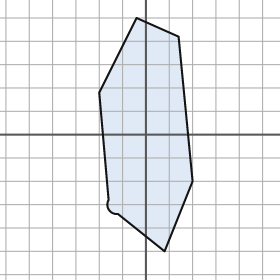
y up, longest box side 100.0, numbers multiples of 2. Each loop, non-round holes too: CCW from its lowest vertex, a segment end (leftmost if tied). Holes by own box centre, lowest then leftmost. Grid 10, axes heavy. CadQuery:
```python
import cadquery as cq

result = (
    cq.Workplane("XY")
    .moveTo(8.0, -50.0)
    .lineTo(20.0, -20.0)
    .lineTo(14.0, 42.0)
    .lineTo(-4.0, 50.0)
    .lineTo(-20.0, 18.0)
    .lineTo(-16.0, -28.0)
    .threePointArc((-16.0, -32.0), (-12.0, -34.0))
    .close()
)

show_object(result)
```